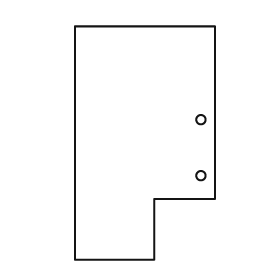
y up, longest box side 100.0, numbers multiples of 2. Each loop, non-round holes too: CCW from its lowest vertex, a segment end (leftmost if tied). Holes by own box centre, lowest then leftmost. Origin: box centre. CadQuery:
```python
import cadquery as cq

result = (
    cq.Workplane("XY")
    .moveTo(-30.0, -50.0)
    .lineTo(4.0, -50.0)
    .lineTo(4.0, -24.0)
    .lineTo(30.0, -24.0)
    .lineTo(30.0, 50.0)
    .lineTo(-30.0, 50.0)
    .close()
    .moveTo(24.0, -14.0)
    .circle(2.0)
    .moveTo(24.0, 10.0)
    .circle(2.0)
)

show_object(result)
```